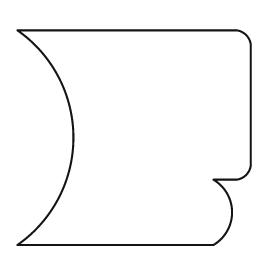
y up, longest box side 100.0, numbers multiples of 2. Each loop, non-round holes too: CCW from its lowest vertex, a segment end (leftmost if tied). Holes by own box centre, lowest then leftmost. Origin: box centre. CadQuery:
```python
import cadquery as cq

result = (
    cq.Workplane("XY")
    .moveTo(-50.0, -46.0)
    .lineTo(34.0, -46.0)
    .threePointArc((42.0, -32.0), (34.0, -18.0))
    .lineTo(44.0, -18.0)
    .threePointArc((48.0, -16.0), (50.0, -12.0))
    .lineTo(50.0, 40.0)
    .threePointArc((48.0, 44.0), (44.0, 46.0))
    .lineTo(-50.0, 46.0)
    .threePointArc((-26.0, 0.0), (-50.0, -46.0))
    .close()
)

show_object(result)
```